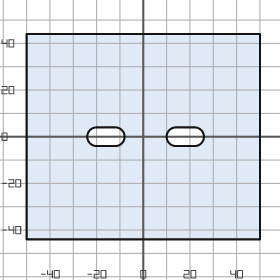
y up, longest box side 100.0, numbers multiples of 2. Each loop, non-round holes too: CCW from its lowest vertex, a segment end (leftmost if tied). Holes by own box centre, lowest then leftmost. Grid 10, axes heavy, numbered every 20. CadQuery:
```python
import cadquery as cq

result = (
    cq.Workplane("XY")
    .moveTo(-50.0, -44.0)
    .lineTo(50.0, -44.0)
    .lineTo(50.0, 44.0)
    .lineTo(-50.0, 44.0)
    .close()
    .moveTo(-20.0, -4.0)
    .lineTo(-12.0, -4.0)
    .threePointArc((-8.0, 0.0), (-12.0, 4.0))
    .lineTo(-20.0, 4.0)
    .threePointArc((-24.0, 0.0), (-20.0, -4.0))
    .close()
    .moveTo(14.0, -4.0)
    .lineTo(22.0, -4.0)
    .threePointArc((26.0, 0.0), (22.0, 4.0))
    .lineTo(14.0, 4.0)
    .threePointArc((10.0, 0.0), (14.0, -4.0))
    .close()
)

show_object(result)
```